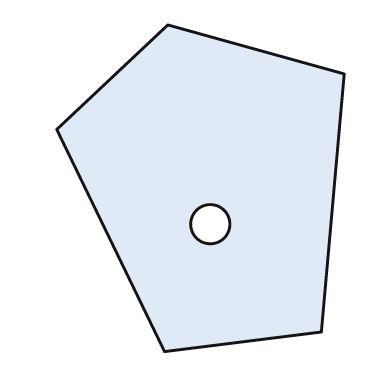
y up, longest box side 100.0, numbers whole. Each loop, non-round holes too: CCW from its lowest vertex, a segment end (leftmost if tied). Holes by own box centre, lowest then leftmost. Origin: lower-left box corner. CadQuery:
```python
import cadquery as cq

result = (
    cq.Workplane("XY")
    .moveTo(33.0, 0.0)
    .lineTo(81.0, 6.0)
    .lineTo(88.0, 85.0)
    .lineTo(34.0, 100.0)
    .lineTo(0.0, 68.0)
    .close()
    .moveTo(47.0, 39.0)
    .circle(6.0)
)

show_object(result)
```